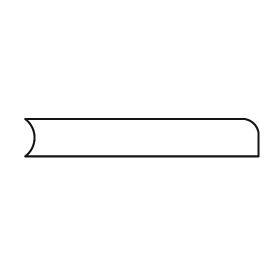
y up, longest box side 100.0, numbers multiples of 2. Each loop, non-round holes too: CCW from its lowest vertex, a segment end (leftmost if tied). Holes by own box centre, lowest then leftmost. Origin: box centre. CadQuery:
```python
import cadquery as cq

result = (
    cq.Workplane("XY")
    .moveTo(-50.0, -8.0)
    .lineTo(50.0, -8.0)
    .lineTo(50.0, 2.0)
    .threePointArc((48.0, 6.0), (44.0, 8.0))
    .lineTo(-50.0, 8.0)
    .threePointArc((-46.0, 0.0), (-50.0, -8.0))
    .close()
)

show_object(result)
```